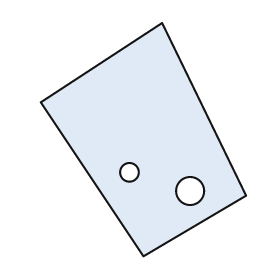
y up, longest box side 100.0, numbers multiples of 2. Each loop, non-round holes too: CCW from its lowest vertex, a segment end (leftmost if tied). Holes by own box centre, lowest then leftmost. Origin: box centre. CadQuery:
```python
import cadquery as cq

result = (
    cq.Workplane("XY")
    .moveTo(0.0, -50.0)
    .lineTo(44.0, -24.0)
    .lineTo(8.0, 50.0)
    .lineTo(-44.0, 16.0)
    .close()
    .moveTo(20.0, -22.0)
    .circle(6.0)
    .moveTo(-6.0, -14.0)
    .circle(4.0)
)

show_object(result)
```